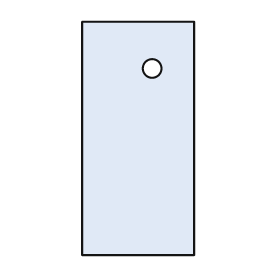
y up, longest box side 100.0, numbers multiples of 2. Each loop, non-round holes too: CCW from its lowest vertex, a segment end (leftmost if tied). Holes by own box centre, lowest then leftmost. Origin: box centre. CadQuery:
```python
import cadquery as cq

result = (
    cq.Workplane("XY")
    .moveTo(-24.0, -50.0)
    .lineTo(24.0, -50.0)
    .lineTo(24.0, 50.0)
    .lineTo(-24.0, 50.0)
    .close()
    .moveTo(6.0, 30.0)
    .circle(4.0)
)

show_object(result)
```